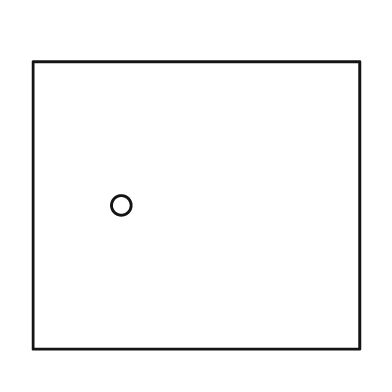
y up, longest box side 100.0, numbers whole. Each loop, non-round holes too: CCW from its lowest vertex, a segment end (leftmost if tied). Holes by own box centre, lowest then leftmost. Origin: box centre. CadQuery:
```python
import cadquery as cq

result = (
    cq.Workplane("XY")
    .moveTo(-50.0, -44.0)
    .lineTo(50.0, -44.0)
    .lineTo(50.0, 44.0)
    .lineTo(-50.0, 44.0)
    .close()
    .moveTo(-23.0, 0.0)
    .circle(3.0)
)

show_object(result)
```